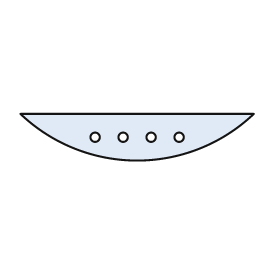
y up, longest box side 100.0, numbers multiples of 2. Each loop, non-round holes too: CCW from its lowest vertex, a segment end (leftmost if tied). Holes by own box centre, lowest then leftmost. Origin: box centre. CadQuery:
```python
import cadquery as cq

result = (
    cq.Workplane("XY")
    .moveTo(-50.0, 10.0)
    .threePointArc((0.0, -10.0), (50.0, 10.0))
    .close()
    .moveTo(-18.0, 0.0)
    .circle(2.0)
    .moveTo(-6.0, 0.0)
    .circle(2.0)
    .moveTo(6.0, 0.0)
    .circle(2.0)
    .moveTo(18.0, 0.0)
    .circle(2.0)
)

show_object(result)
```